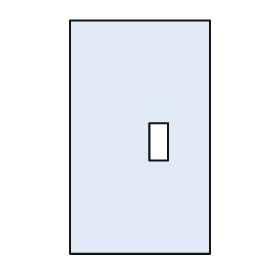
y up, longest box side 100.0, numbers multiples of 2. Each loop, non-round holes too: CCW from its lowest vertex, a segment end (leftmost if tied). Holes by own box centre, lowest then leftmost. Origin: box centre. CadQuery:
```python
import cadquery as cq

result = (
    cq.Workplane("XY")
    .moveTo(-30.0, -50.0)
    .lineTo(30.0, -50.0)
    .lineTo(30.0, 50.0)
    .lineTo(-30.0, 50.0)
    .close()
    .moveTo(4.0, -10.0)
    .lineTo(12.0, -10.0)
    .lineTo(12.0, 6.0)
    .lineTo(4.0, 6.0)
    .close()
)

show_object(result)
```